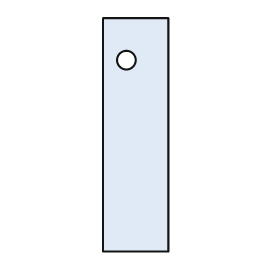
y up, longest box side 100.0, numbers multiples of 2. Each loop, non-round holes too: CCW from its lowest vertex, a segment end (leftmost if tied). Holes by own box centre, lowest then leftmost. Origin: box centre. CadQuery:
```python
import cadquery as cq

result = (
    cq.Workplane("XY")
    .moveTo(-14.0, -50.0)
    .lineTo(14.0, -50.0)
    .lineTo(14.0, 50.0)
    .lineTo(-14.0, 50.0)
    .close()
    .moveTo(-4.0, 32.0)
    .circle(4.0)
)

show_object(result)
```